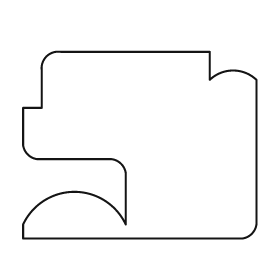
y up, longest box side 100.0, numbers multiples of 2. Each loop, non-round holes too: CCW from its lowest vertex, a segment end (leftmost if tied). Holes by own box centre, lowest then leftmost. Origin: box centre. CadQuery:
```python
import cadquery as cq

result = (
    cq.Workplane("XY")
    .moveTo(-50.0, -40.0)
    .lineTo(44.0, -40.0)
    .threePointArc((48.0, -38.0), (50.0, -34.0))
    .lineTo(50.0, 28.0)
    .threePointArc((40.0, 32.0), (30.0, 28.0))
    .lineTo(30.0, 40.0)
    .lineTo(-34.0, 40.0)
    .threePointArc((-40.0, 38.0), (-42.0, 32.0))
    .lineTo(-42.0, 16.0)
    .lineTo(-50.0, 16.0)
    .lineTo(-50.0, 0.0)
    .threePointArc((-48.0, -4.0), (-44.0, -6.0))
    .lineTo(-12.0, -6.0)
    .threePointArc((-8.0, -8.0), (-6.0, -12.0))
    .lineTo(-6.0, -34.0)
    .threePointArc((-28.0, -20.0), (-50.0, -34.0))
    .close()
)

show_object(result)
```